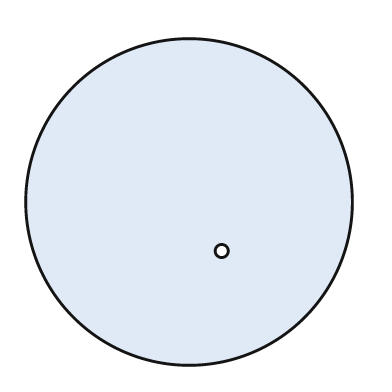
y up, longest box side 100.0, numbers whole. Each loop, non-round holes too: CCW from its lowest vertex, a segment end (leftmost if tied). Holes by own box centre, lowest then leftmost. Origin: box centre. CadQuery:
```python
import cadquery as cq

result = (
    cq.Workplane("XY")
    .moveTo(0.0, 0.0)
    .circle(50.0)
    .moveTo(10.0, -15.0)
    .circle(2.0)
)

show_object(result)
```